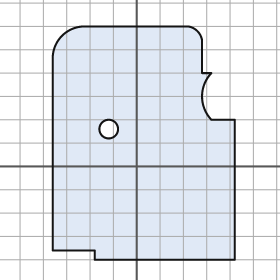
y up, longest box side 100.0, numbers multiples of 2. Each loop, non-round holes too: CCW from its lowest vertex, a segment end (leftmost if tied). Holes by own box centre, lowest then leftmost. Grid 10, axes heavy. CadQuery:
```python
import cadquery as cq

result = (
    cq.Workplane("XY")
    .moveTo(-18.0, -40.0)
    .lineTo(42.0, -40.0)
    .lineTo(42.0, 20.0)
    .lineTo(32.0, 20.0)
    .threePointArc((28.0, 30.0), (32.0, 40.0))
    .lineTo(28.0, 40.0)
    .lineTo(28.0, 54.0)
    .threePointArc((26.0, 58.0), (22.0, 60.0))
    .lineTo(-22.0, 60.0)
    .threePointArc((-32.0, 56.0), (-36.0, 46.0))
    .lineTo(-36.0, -36.0)
    .lineTo(-18.0, -36.0)
    .close()
    .moveTo(-12.0, 16.0)
    .circle(4.0)
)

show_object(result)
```